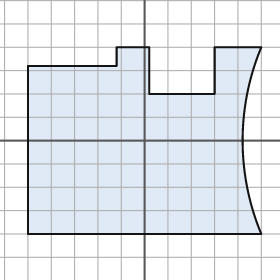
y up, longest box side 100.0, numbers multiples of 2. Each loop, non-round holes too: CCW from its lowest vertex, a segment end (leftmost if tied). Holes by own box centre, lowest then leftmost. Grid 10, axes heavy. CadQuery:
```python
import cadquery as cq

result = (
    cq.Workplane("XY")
    .moveTo(-50.0, -40.0)
    .lineTo(50.0, -40.0)
    .threePointArc((42.0, 0.0), (50.0, 40.0))
    .lineTo(30.0, 40.0)
    .lineTo(30.0, 20.0)
    .lineTo(2.0, 20.0)
    .lineTo(2.0, 40.0)
    .lineTo(-12.0, 40.0)
    .lineTo(-12.0, 32.0)
    .lineTo(-50.0, 32.0)
    .close()
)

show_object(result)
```